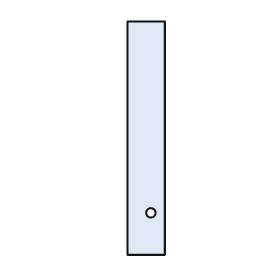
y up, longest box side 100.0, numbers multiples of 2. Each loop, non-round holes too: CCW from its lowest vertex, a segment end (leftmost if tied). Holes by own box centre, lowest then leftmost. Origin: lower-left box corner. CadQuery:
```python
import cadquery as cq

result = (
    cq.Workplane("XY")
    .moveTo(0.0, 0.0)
    .lineTo(16.0, 0.0)
    .lineTo(16.0, 100.0)
    .lineTo(0.0, 100.0)
    .close()
    .moveTo(10.0, 18.0)
    .circle(2.0)
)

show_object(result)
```